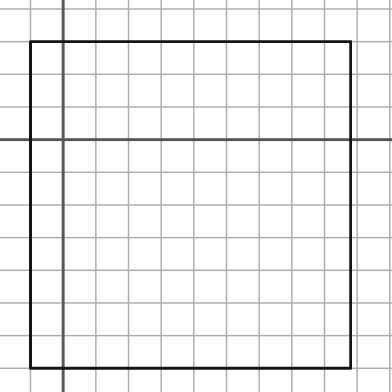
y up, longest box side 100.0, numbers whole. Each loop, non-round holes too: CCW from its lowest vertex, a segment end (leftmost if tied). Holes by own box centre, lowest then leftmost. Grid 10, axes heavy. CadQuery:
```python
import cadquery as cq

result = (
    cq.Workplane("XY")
    .moveTo(-10.0, -70.0)
    .lineTo(88.0, -70.0)
    .lineTo(88.0, 30.0)
    .lineTo(-10.0, 30.0)
    .close()
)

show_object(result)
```